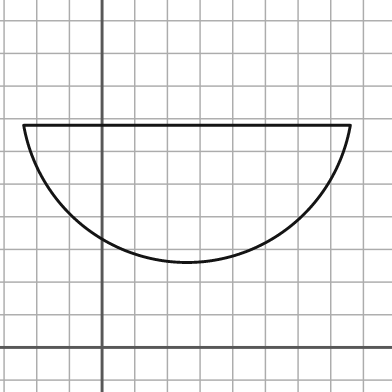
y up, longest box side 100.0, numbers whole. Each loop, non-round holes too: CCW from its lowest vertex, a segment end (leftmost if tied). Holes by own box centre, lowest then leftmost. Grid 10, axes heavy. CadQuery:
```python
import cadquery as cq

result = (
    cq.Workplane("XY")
    .moveTo(-24.0, 68.0)
    .threePointArc((26.0, 26.0), (76.0, 68.0))
    .close()
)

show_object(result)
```